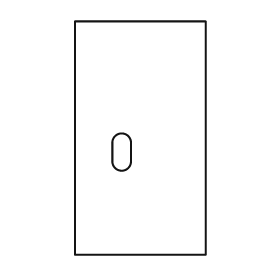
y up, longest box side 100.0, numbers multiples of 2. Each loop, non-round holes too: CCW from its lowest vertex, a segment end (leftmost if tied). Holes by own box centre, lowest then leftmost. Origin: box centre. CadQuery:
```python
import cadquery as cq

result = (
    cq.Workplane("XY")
    .moveTo(-28.0, -50.0)
    .lineTo(28.0, -50.0)
    .lineTo(28.0, 50.0)
    .lineTo(-28.0, 50.0)
    .close()
    .moveTo(-12.0, -10.0)
    .threePointArc((-8.0, -14.0), (-4.0, -10.0))
    .lineTo(-4.0, -2.0)
    .threePointArc((-8.0, 2.0), (-12.0, -2.0))
    .close()
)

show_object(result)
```